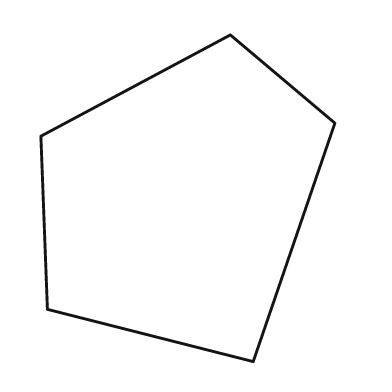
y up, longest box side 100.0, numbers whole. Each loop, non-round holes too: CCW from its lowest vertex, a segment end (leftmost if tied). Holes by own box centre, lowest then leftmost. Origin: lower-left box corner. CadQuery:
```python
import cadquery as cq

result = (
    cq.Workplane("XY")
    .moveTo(65.0, 0.0)
    .lineTo(90.0, 73.0)
    .lineTo(58.0, 100.0)
    .lineTo(0.0, 69.0)
    .lineTo(2.0, 16.0)
    .close()
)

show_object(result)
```